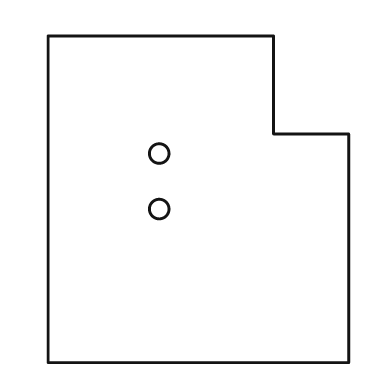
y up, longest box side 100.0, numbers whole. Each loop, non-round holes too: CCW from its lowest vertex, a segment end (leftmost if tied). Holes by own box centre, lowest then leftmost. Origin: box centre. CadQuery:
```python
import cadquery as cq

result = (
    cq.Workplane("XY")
    .moveTo(-46.0, -50.0)
    .lineTo(46.0, -50.0)
    .lineTo(46.0, 20.0)
    .lineTo(23.0, 20.0)
    .lineTo(23.0, 50.0)
    .lineTo(-46.0, 50.0)
    .close()
    .moveTo(-12.0, -3.0)
    .circle(3.0)
    .moveTo(-12.0, 14.0)
    .circle(3.0)
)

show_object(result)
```